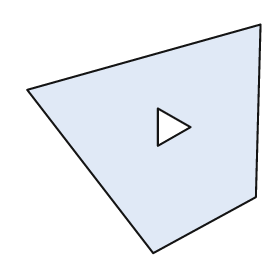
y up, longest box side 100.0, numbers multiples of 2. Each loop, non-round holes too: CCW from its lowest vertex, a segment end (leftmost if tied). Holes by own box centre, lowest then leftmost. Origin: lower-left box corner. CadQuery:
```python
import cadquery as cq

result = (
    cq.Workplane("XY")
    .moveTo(54.0, 0.0)
    .lineTo(98.0, 24.0)
    .lineTo(100.0, 98.0)
    .lineTo(0.0, 70.0)
    .close()
    .moveTo(56.0, 46.0)
    .lineTo(70.0, 54.0)
    .lineTo(56.0, 62.0)
    .close()
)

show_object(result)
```